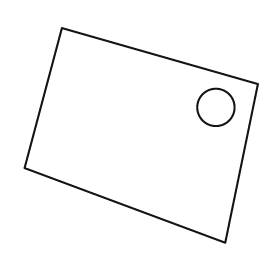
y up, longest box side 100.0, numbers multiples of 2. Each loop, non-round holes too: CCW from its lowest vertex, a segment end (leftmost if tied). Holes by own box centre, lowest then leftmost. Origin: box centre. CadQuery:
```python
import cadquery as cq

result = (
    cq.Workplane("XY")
    .moveTo(36.0, -46.0)
    .lineTo(50.0, 22.0)
    .lineTo(-34.0, 46.0)
    .lineTo(-50.0, -14.0)
    .close()
    .moveTo(32.0, 12.0)
    .circle(8.0)
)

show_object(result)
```